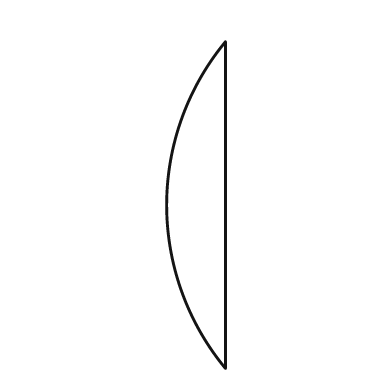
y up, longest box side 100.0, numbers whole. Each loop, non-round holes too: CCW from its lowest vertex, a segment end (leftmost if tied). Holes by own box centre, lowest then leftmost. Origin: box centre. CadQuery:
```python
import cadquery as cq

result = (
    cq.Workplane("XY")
    .moveTo(9.0, -50.0)
    .lineTo(9.0, 50.0)
    .threePointArc((-9.0, 0.0), (9.0, -50.0))
    .close()
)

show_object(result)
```